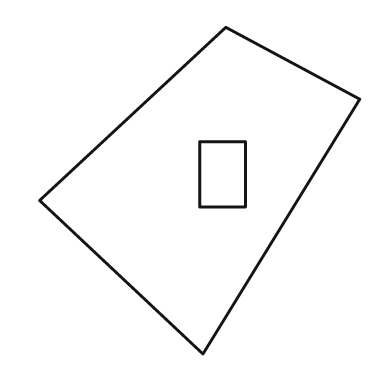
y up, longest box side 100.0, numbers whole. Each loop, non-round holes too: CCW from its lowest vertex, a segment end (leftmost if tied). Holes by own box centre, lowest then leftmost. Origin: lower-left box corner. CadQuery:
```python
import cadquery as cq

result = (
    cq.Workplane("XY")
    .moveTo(50.0, 0.0)
    .lineTo(98.0, 78.0)
    .lineTo(57.0, 100.0)
    .lineTo(0.0, 47.0)
    .close()
    .moveTo(49.0, 45.0)
    .lineTo(63.0, 45.0)
    .lineTo(63.0, 65.0)
    .lineTo(49.0, 65.0)
    .close()
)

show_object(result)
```